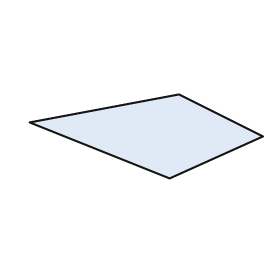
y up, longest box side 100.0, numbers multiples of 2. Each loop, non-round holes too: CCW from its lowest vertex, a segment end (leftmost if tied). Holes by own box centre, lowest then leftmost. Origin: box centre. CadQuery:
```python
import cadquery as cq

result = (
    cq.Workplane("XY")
    .moveTo(10.0, -18.0)
    .lineTo(50.0, 0.0)
    .lineTo(14.0, 18.0)
    .lineTo(-50.0, 6.0)
    .close()
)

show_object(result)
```